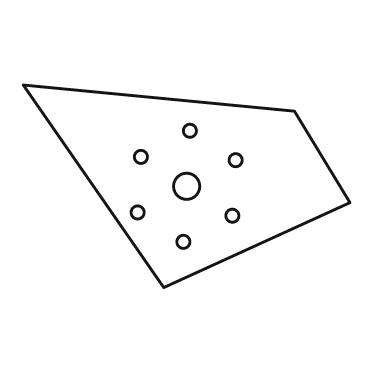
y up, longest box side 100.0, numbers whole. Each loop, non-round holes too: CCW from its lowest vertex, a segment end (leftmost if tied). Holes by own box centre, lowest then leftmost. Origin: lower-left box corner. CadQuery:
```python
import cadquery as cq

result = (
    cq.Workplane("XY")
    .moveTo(43.0, 0.0)
    .lineTo(100.0, 26.0)
    .lineTo(83.0, 54.0)
    .lineTo(0.0, 62.0)
    .close()
    .moveTo(49.0, 14.0)
    .circle(2.0)
    .moveTo(64.0, 22.0)
    .circle(2.0)
    .moveTo(35.0, 23.0)
    .circle(2.0)
    .moveTo(50.0, 31.0)
    .circle(4.0)
    .moveTo(65.0, 39.0)
    .circle(2.0)
    .moveTo(36.0, 40.0)
    .circle(2.0)
    .moveTo(51.0, 48.0)
    .circle(2.0)
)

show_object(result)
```